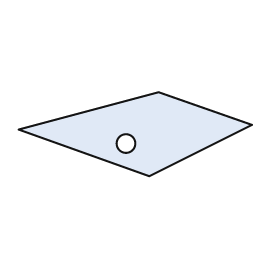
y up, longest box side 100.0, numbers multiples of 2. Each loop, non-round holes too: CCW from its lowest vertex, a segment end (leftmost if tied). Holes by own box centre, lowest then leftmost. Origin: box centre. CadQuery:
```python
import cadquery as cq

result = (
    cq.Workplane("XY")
    .moveTo(6.0, -18.0)
    .lineTo(50.0, 4.0)
    .lineTo(10.0, 18.0)
    .lineTo(-50.0, 2.0)
    .close()
    .moveTo(-4.0, -4.0)
    .circle(4.0)
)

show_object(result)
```